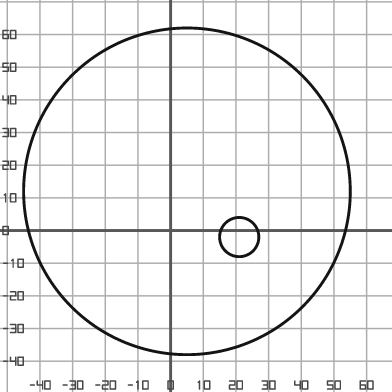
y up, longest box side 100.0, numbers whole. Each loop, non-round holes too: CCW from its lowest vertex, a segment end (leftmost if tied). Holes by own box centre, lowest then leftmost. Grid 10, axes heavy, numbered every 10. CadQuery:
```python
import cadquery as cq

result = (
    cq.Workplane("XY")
    .moveTo(5.0, 12.0)
    .circle(50.0)
    .moveTo(21.0, -2.0)
    .circle(6.0)
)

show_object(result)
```